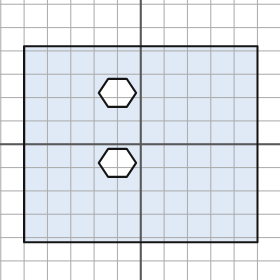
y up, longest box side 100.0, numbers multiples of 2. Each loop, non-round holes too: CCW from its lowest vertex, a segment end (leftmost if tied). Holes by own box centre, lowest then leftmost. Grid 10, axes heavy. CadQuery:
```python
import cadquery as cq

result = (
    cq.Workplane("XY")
    .moveTo(-50.0, -42.0)
    .lineTo(50.0, -42.0)
    .lineTo(50.0, 42.0)
    .lineTo(-50.0, 42.0)
    .close()
    .moveTo(-14.0, -14.0)
    .lineTo(-6.0, -14.0)
    .lineTo(-2.0, -8.0)
    .lineTo(-6.0, -2.0)
    .lineTo(-14.0, -2.0)
    .lineTo(-18.0, -8.0)
    .close()
    .moveTo(-14.0, 16.0)
    .lineTo(-6.0, 16.0)
    .lineTo(-2.0, 22.0)
    .lineTo(-6.0, 28.0)
    .lineTo(-14.0, 28.0)
    .lineTo(-18.0, 22.0)
    .close()
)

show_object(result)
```